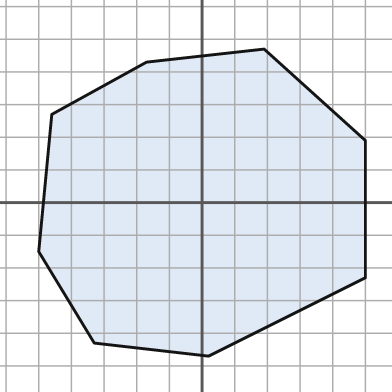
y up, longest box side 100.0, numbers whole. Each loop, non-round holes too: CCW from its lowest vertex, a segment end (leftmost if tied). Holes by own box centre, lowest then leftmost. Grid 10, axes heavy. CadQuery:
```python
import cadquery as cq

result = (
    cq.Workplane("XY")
    .moveTo(2.0, -47.0)
    .lineTo(50.0, -23.0)
    .lineTo(50.0, 19.0)
    .lineTo(19.0, 47.0)
    .lineTo(-17.0, 43.0)
    .lineTo(-46.0, 27.0)
    .lineTo(-50.0, -15.0)
    .lineTo(-33.0, -43.0)
    .close()
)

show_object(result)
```